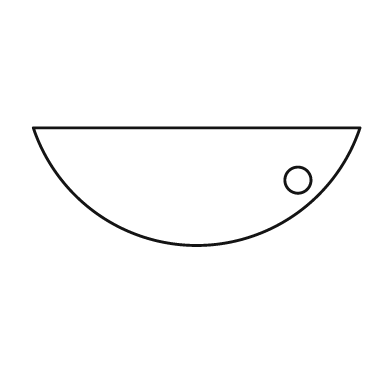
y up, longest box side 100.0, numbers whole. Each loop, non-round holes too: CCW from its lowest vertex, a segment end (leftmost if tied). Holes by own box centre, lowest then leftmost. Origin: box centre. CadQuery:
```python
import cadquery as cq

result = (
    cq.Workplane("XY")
    .moveTo(-50.0, 18.0)
    .threePointArc((0.0, -18.0), (50.0, 18.0))
    .close()
    .moveTo(31.0, 2.0)
    .circle(4.0)
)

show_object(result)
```